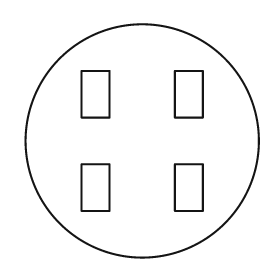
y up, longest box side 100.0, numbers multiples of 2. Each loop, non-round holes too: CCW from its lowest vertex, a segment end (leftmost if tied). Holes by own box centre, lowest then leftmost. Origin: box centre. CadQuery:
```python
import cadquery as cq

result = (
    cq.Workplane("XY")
    .moveTo(0.0, 0.0)
    .circle(50.0)
    .moveTo(-26.0, -30.0)
    .lineTo(-14.0, -30.0)
    .lineTo(-14.0, -10.0)
    .lineTo(-26.0, -10.0)
    .close()
    .moveTo(14.0, -30.0)
    .lineTo(26.0, -30.0)
    .lineTo(26.0, -10.0)
    .lineTo(14.0, -10.0)
    .close()
    .moveTo(-26.0, 10.0)
    .lineTo(-14.0, 10.0)
    .lineTo(-14.0, 30.0)
    .lineTo(-26.0, 30.0)
    .close()
    .moveTo(14.0, 10.0)
    .lineTo(26.0, 10.0)
    .lineTo(26.0, 30.0)
    .lineTo(14.0, 30.0)
    .close()
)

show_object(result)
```